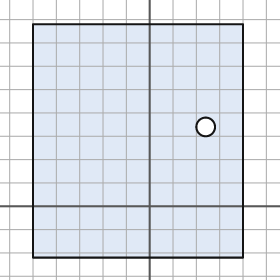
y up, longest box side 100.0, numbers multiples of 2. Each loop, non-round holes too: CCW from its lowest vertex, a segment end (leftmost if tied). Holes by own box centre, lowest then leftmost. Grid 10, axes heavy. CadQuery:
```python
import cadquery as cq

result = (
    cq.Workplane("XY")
    .moveTo(-50.0, -22.0)
    .lineTo(40.0, -22.0)
    .lineTo(40.0, 78.0)
    .lineTo(-50.0, 78.0)
    .close()
    .moveTo(24.0, 34.0)
    .circle(4.0)
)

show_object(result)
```